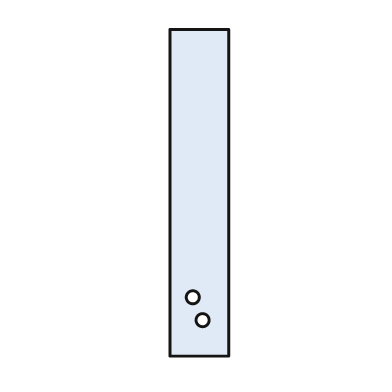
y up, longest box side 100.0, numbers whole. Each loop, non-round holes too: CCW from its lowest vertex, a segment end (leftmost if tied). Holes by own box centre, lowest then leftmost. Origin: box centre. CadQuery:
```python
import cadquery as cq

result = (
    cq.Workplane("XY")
    .moveTo(-9.0, -50.0)
    .lineTo(9.0, -50.0)
    .lineTo(9.0, 50.0)
    .lineTo(-9.0, 50.0)
    .close()
    .moveTo(1.0, -39.0)
    .circle(2.0)
    .moveTo(-2.0, -32.0)
    .circle(2.0)
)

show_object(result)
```